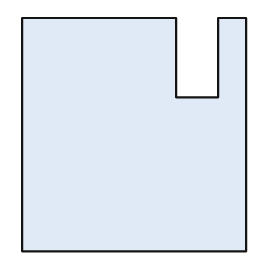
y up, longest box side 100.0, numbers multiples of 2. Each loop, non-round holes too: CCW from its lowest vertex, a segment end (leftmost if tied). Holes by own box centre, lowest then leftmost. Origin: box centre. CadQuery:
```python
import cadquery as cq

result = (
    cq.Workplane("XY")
    .moveTo(-48.0, -50.0)
    .lineTo(48.0, -50.0)
    .lineTo(48.0, 50.0)
    .lineTo(36.0, 50.0)
    .lineTo(36.0, 16.0)
    .lineTo(18.0, 16.0)
    .lineTo(18.0, 50.0)
    .lineTo(-48.0, 50.0)
    .close()
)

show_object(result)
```